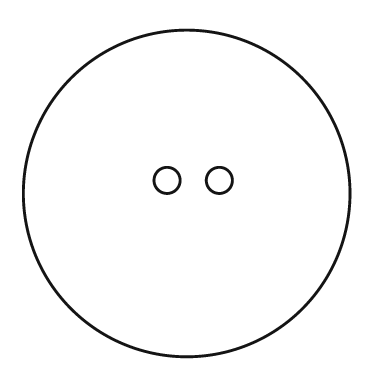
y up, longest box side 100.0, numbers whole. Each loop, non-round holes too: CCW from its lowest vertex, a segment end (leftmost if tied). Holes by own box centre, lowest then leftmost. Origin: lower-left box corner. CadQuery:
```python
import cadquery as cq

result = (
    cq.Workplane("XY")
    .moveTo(50.0, 50.0)
    .circle(50.0)
    .moveTo(44.0, 54.0)
    .circle(4.0)
    .moveTo(60.0, 54.0)
    .circle(4.0)
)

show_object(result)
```